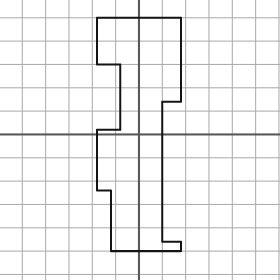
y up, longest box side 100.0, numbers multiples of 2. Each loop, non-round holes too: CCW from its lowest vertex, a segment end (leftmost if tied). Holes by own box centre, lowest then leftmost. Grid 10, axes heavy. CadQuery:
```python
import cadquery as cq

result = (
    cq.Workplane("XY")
    .moveTo(-12.0, -50.0)
    .lineTo(18.0, -50.0)
    .lineTo(18.0, -46.0)
    .lineTo(10.0, -46.0)
    .lineTo(10.0, 14.0)
    .lineTo(18.0, 14.0)
    .lineTo(18.0, 50.0)
    .lineTo(-18.0, 50.0)
    .lineTo(-18.0, 30.0)
    .lineTo(-8.0, 30.0)
    .lineTo(-8.0, 2.0)
    .lineTo(-18.0, 2.0)
    .lineTo(-18.0, -24.0)
    .lineTo(-12.0, -24.0)
    .close()
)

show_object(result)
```